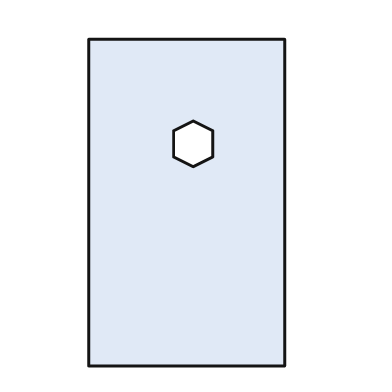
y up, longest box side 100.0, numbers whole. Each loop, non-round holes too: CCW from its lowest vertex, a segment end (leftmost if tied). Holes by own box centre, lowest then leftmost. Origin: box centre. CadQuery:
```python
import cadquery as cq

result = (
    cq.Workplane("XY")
    .moveTo(-30.0, -50.0)
    .lineTo(30.0, -50.0)
    .lineTo(30.0, 50.0)
    .lineTo(-30.0, 50.0)
    .close()
    .moveTo(2.0, 11.0)
    .lineTo(8.0, 14.0)
    .lineTo(8.0, 22.0)
    .lineTo(2.0, 25.0)
    .lineTo(-4.0, 22.0)
    .lineTo(-4.0, 14.0)
    .close()
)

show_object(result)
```